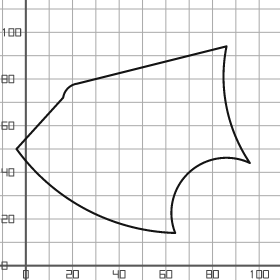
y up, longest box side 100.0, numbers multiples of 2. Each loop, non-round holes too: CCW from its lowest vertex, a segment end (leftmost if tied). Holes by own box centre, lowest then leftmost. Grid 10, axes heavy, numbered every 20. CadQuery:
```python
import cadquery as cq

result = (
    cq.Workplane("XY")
    .moveTo(64.0, 14.0)
    .threePointArc((70.0, 40.0), (96.0, 44.0))
    .threePointArc((86.0, 68.0), (86.0, 94.0))
    .lineTo(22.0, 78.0)
    .threePointArc((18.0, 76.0), (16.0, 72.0))
    .lineTo(-4.0, 50.0)
    .threePointArc((26.0, 24.0), (64.0, 14.0))
    .close()
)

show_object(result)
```